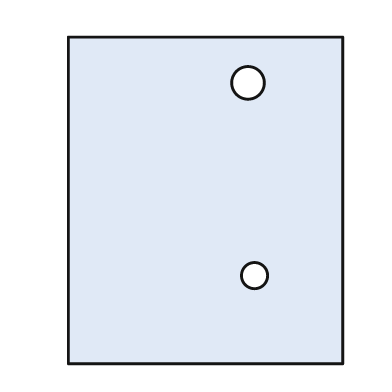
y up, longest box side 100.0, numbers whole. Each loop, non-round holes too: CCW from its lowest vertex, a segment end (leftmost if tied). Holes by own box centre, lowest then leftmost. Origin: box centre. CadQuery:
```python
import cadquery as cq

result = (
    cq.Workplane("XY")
    .moveTo(-42.0, -50.0)
    .lineTo(42.0, -50.0)
    .lineTo(42.0, 50.0)
    .lineTo(-42.0, 50.0)
    .close()
    .moveTo(15.0, -23.0)
    .circle(4.0)
    .moveTo(13.0, 36.0)
    .circle(5.0)
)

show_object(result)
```